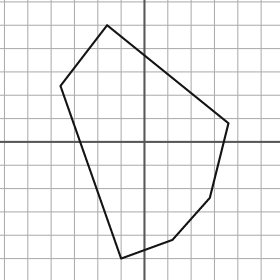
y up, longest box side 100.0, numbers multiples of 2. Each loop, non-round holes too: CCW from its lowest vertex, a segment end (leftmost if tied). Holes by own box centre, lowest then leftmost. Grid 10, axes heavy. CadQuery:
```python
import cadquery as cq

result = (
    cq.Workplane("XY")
    .moveTo(-10.0, -50.0)
    .lineTo(12.0, -42.0)
    .lineTo(28.0, -24.0)
    .lineTo(36.0, 8.0)
    .lineTo(-16.0, 50.0)
    .lineTo(-36.0, 24.0)
    .close()
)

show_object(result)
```